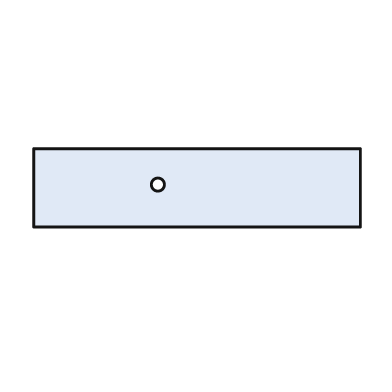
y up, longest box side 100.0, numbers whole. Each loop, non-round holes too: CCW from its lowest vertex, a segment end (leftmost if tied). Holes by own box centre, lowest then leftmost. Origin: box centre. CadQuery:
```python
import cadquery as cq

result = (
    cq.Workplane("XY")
    .moveTo(-50.0, -12.0)
    .lineTo(50.0, -12.0)
    .lineTo(50.0, 12.0)
    .lineTo(-50.0, 12.0)
    .close()
    .moveTo(-12.0, 1.0)
    .circle(2.0)
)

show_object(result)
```